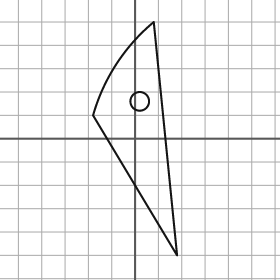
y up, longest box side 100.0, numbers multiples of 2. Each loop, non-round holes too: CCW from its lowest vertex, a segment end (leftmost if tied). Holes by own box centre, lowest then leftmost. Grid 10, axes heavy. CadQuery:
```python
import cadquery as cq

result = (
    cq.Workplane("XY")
    .moveTo(18.0, -50.0)
    .lineTo(8.0, 50.0)
    .threePointArc((-8.0, 32.0), (-18.0, 10.0))
    .close()
    .moveTo(2.0, 16.0)
    .circle(4.0)
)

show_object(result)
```